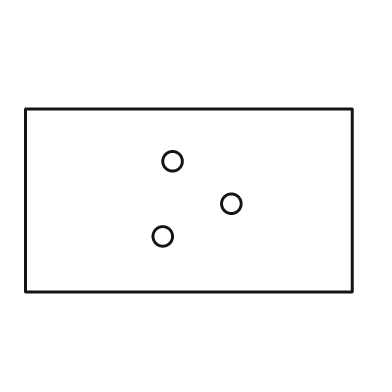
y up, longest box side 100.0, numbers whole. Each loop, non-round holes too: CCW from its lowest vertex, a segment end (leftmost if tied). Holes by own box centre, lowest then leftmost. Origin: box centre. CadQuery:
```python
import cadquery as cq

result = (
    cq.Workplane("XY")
    .moveTo(-50.0, -28.0)
    .lineTo(50.0, -28.0)
    .lineTo(50.0, 28.0)
    .lineTo(-50.0, 28.0)
    .close()
    .moveTo(-8.0, -11.0)
    .circle(3.0)
    .moveTo(13.0, -1.0)
    .circle(3.0)
    .moveTo(-5.0, 12.0)
    .circle(3.0)
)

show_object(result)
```